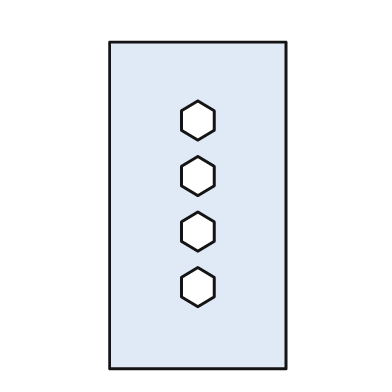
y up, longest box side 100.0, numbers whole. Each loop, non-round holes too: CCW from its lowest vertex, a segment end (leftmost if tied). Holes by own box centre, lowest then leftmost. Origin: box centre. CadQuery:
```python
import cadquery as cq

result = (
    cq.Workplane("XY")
    .moveTo(-27.0, -50.0)
    .lineTo(27.0, -50.0)
    .lineTo(27.0, 50.0)
    .lineTo(-27.0, 50.0)
    .close()
    .moveTo(0.0, -31.0)
    .lineTo(5.0, -28.0)
    .lineTo(5.0, -22.0)
    .lineTo(0.0, -19.0)
    .lineTo(-5.0, -22.0)
    .lineTo(-5.0, -28.0)
    .close()
    .moveTo(0.0, -14.0)
    .lineTo(5.0, -11.0)
    .lineTo(5.0, -5.0)
    .lineTo(0.0, -2.0)
    .lineTo(-5.0, -5.0)
    .lineTo(-5.0, -11.0)
    .close()
    .moveTo(0.0, 3.0)
    .lineTo(5.0, 6.0)
    .lineTo(5.0, 12.0)
    .lineTo(0.0, 15.0)
    .lineTo(-5.0, 12.0)
    .lineTo(-5.0, 6.0)
    .close()
    .moveTo(0.0, 20.0)
    .lineTo(5.0, 23.0)
    .lineTo(5.0, 29.0)
    .lineTo(0.0, 32.0)
    .lineTo(-5.0, 29.0)
    .lineTo(-5.0, 23.0)
    .close()
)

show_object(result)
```